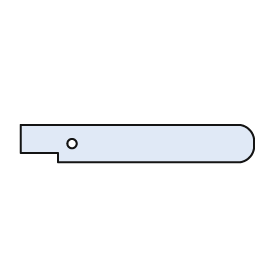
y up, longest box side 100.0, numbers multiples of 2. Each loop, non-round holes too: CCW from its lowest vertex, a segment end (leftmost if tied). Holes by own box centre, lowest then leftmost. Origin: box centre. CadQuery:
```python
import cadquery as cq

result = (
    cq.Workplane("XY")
    .moveTo(-34.0, -8.0)
    .lineTo(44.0, -8.0)
    .threePointArc((48.0, -6.0), (50.0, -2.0))
    .lineTo(50.0, 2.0)
    .threePointArc((48.0, 6.0), (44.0, 8.0))
    .lineTo(-50.0, 8.0)
    .lineTo(-50.0, -4.0)
    .lineTo(-34.0, -4.0)
    .close()
    .moveTo(-28.0, 0.0)
    .circle(2.0)
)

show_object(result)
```